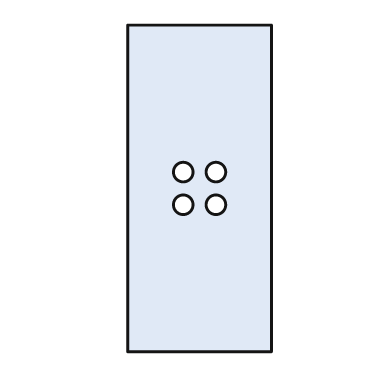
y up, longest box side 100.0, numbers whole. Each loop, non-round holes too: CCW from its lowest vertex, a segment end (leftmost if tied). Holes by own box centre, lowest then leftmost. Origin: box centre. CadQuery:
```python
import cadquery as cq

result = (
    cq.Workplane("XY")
    .moveTo(-22.0, -50.0)
    .lineTo(22.0, -50.0)
    .lineTo(22.0, 50.0)
    .lineTo(-22.0, 50.0)
    .close()
    .moveTo(-5.0, -5.0)
    .circle(3.0)
    .moveTo(5.0, -5.0)
    .circle(3.0)
    .moveTo(-5.0, 5.0)
    .circle(3.0)
    .moveTo(5.0, 5.0)
    .circle(3.0)
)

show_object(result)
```